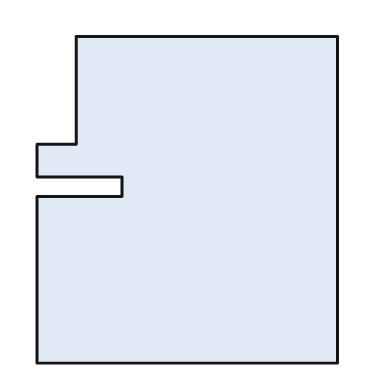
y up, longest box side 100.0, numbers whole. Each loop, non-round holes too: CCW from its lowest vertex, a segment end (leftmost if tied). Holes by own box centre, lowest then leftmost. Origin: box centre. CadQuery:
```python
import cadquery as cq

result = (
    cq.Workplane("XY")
    .moveTo(-46.0, -50.0)
    .lineTo(46.0, -50.0)
    .lineTo(46.0, 50.0)
    .lineTo(-34.0, 50.0)
    .lineTo(-34.0, 17.0)
    .lineTo(-46.0, 17.0)
    .lineTo(-46.0, 7.0)
    .lineTo(-20.0, 7.0)
    .lineTo(-20.0, 1.0)
    .lineTo(-46.0, 1.0)
    .close()
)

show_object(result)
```